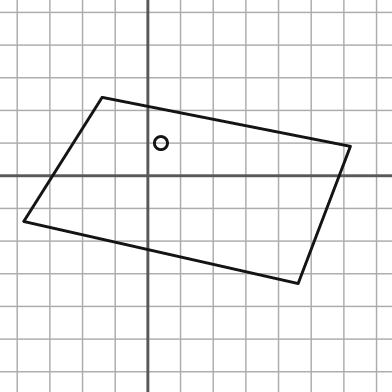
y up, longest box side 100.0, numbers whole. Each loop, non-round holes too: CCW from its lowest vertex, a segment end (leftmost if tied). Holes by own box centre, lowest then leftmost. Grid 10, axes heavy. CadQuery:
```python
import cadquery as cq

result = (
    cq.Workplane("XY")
    .moveTo(46.0, -33.0)
    .lineTo(62.0, 9.0)
    .lineTo(-14.0, 24.0)
    .lineTo(-38.0, -14.0)
    .close()
    .moveTo(4.0, 10.0)
    .circle(2.0)
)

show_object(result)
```